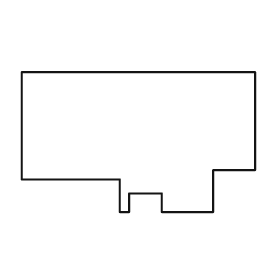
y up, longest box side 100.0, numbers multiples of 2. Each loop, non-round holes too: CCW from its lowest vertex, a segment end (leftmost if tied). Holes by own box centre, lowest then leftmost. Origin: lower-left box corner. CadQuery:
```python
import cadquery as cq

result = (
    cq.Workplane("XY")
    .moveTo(42.0, 0.0)
    .lineTo(46.0, 0.0)
    .lineTo(46.0, 8.0)
    .lineTo(60.0, 8.0)
    .lineTo(60.0, 0.0)
    .lineTo(82.0, 0.0)
    .lineTo(82.0, 18.0)
    .lineTo(100.0, 18.0)
    .lineTo(100.0, 60.0)
    .lineTo(0.0, 60.0)
    .lineTo(0.0, 14.0)
    .lineTo(42.0, 14.0)
    .close()
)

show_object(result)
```